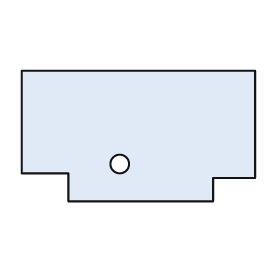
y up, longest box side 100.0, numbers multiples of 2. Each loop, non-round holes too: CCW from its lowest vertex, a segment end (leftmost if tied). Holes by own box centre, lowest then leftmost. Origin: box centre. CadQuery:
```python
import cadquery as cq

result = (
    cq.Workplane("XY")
    .moveTo(-30.0, -28.0)
    .lineTo(32.0, -28.0)
    .lineTo(32.0, -18.0)
    .lineTo(50.0, -18.0)
    .lineTo(50.0, 28.0)
    .lineTo(-50.0, 28.0)
    .lineTo(-50.0, -16.0)
    .lineTo(-30.0, -16.0)
    .close()
    .moveTo(-8.0, -12.0)
    .circle(4.0)
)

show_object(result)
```